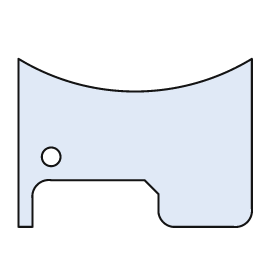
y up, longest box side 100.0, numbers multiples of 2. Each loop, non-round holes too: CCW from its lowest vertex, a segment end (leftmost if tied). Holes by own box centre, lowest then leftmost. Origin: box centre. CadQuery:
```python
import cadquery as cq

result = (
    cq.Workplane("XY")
    .moveTo(-50.0, -36.0)
    .lineTo(-44.0, -36.0)
    .lineTo(-44.0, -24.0)
    .threePointArc((-42.0, -18.0), (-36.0, -16.0))
    .lineTo(4.0, -16.0)
    .lineTo(10.0, -22.0)
    .lineTo(10.0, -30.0)
    .threePointArc((12.0, -34.0), (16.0, -36.0))
    .lineTo(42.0, -36.0)
    .threePointArc((48.0, -34.0), (50.0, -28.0))
    .lineTo(50.0, 36.0)
    .threePointArc((0.0, 22.0), (-50.0, 36.0))
    .close()
    .moveTo(-36.0, -6.0)
    .circle(4.0)
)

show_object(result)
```